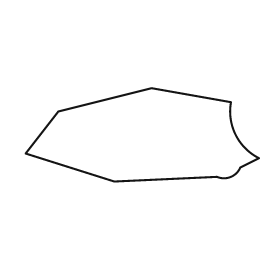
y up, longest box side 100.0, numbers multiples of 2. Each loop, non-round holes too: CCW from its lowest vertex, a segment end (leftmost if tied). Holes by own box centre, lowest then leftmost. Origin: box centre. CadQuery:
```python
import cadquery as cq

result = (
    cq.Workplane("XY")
    .moveTo(-12.0, -20.0)
    .lineTo(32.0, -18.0)
    .threePointArc((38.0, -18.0), (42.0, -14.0))
    .lineTo(50.0, -10.0)
    .threePointArc((40.0, 0.0), (38.0, 14.0))
    .lineTo(4.0, 20.0)
    .lineTo(-36.0, 10.0)
    .lineTo(-50.0, -8.0)
    .close()
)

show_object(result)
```